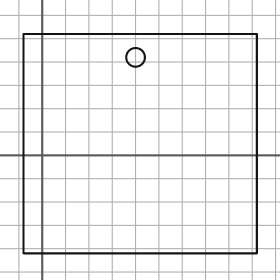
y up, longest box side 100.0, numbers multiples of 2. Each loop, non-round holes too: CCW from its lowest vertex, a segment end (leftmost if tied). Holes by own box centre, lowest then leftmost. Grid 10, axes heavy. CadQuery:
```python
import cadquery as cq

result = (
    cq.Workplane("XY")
    .moveTo(-8.0, -42.0)
    .lineTo(92.0, -42.0)
    .lineTo(92.0, 52.0)
    .lineTo(-8.0, 52.0)
    .close()
    .moveTo(40.0, 42.0)
    .circle(4.0)
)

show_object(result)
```